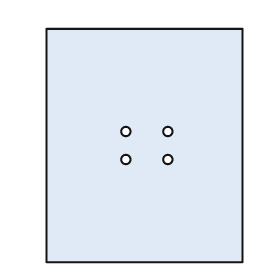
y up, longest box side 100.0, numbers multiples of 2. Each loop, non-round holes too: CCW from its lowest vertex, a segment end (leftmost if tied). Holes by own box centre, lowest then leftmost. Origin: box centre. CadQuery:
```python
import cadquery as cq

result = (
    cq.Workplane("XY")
    .moveTo(-42.0, -50.0)
    .lineTo(42.0, -50.0)
    .lineTo(42.0, 50.0)
    .lineTo(-42.0, 50.0)
    .close()
    .moveTo(-8.0, -6.0)
    .circle(2.0)
    .moveTo(10.0, -6.0)
    .circle(2.0)
    .moveTo(-8.0, 6.0)
    .circle(2.0)
    .moveTo(10.0, 6.0)
    .circle(2.0)
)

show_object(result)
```